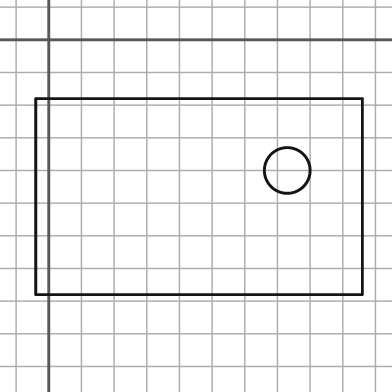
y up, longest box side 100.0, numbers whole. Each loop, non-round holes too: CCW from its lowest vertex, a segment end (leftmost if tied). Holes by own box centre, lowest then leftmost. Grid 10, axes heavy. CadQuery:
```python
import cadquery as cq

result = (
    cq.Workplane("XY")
    .moveTo(-4.0, -78.0)
    .lineTo(96.0, -78.0)
    .lineTo(96.0, -18.0)
    .lineTo(-4.0, -18.0)
    .close()
    .moveTo(73.0, -40.0)
    .circle(7.0)
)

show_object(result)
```